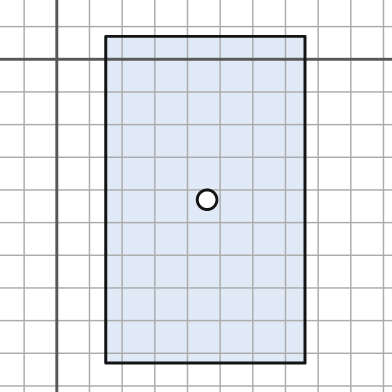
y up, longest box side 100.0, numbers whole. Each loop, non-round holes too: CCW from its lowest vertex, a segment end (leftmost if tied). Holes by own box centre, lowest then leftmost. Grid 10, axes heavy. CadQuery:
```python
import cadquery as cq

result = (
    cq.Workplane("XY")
    .moveTo(15.0, -93.0)
    .lineTo(76.0, -93.0)
    .lineTo(76.0, 7.0)
    .lineTo(15.0, 7.0)
    .close()
    .moveTo(46.0, -43.0)
    .circle(3.0)
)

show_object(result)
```